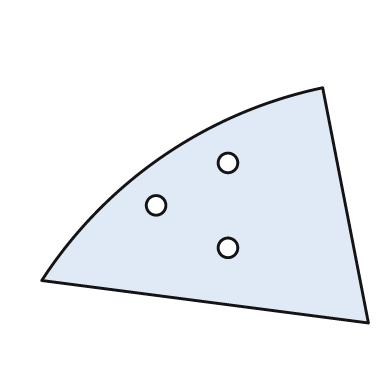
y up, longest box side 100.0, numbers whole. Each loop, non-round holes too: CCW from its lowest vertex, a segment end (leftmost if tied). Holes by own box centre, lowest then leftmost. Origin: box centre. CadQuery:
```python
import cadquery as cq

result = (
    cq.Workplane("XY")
    .moveTo(50.0, -36.0)
    .lineTo(36.0, 36.0)
    .threePointArc((-13.0, 15.0), (-50.0, -23.0))
    .close()
    .moveTo(7.0, -13.0)
    .circle(3.0)
    .moveTo(-15.0, 0.0)
    .circle(3.0)
    .moveTo(7.0, 13.0)
    .circle(3.0)
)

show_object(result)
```